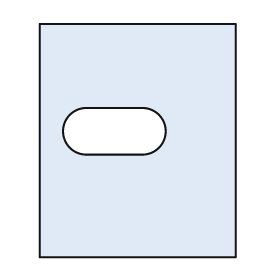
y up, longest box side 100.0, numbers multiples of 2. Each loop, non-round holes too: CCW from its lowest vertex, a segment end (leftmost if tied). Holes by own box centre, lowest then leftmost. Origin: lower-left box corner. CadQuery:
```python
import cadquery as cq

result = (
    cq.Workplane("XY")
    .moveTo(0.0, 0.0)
    .lineTo(84.0, 0.0)
    .lineTo(84.0, 100.0)
    .lineTo(0.0, 100.0)
    .close()
    .moveTo(20.0, 44.0)
    .lineTo(44.0, 44.0)
    .threePointArc((54.0, 54.0), (44.0, 64.0))
    .lineTo(20.0, 64.0)
    .threePointArc((10.0, 54.0), (20.0, 44.0))
    .close()
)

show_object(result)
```